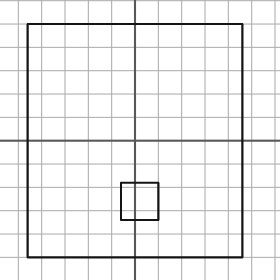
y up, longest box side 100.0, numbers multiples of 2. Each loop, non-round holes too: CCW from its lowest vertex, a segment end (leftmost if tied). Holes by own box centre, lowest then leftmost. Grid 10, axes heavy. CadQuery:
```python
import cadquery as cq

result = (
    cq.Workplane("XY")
    .moveTo(-46.0, -50.0)
    .lineTo(46.0, -50.0)
    .lineTo(46.0, 50.0)
    .lineTo(-46.0, 50.0)
    .close()
    .moveTo(-6.0, -34.0)
    .lineTo(10.0, -34.0)
    .lineTo(10.0, -18.0)
    .lineTo(-6.0, -18.0)
    .close()
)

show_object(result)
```